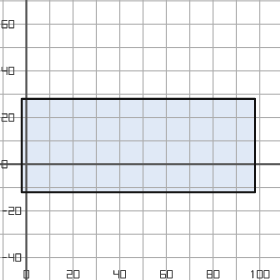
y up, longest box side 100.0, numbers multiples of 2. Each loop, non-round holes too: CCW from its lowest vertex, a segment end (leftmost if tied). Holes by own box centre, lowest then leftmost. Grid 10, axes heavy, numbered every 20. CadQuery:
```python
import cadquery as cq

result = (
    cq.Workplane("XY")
    .moveTo(-2.0, -12.0)
    .lineTo(98.0, -12.0)
    .lineTo(98.0, 28.0)
    .lineTo(-2.0, 28.0)
    .close()
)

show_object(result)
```